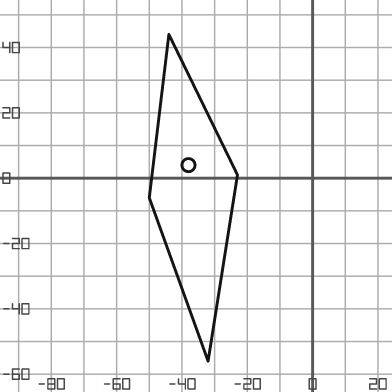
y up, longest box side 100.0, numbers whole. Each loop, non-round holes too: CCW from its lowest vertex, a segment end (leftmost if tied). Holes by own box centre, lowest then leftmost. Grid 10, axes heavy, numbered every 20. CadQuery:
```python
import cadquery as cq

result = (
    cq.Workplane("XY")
    .moveTo(-32.0, -56.0)
    .lineTo(-23.0, 1.0)
    .lineTo(-44.0, 44.0)
    .lineTo(-50.0, -6.0)
    .close()
    .moveTo(-38.0, 4.0)
    .circle(2.0)
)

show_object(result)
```